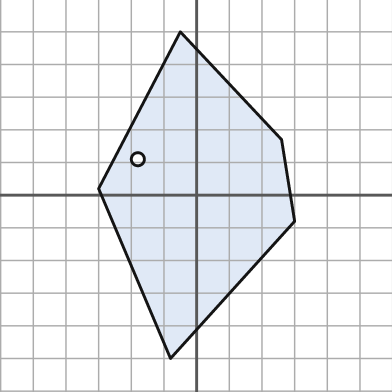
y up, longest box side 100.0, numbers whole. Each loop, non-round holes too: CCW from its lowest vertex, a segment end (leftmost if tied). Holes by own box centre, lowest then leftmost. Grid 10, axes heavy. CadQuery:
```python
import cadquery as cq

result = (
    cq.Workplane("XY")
    .moveTo(-8.0, -50.0)
    .lineTo(30.0, -8.0)
    .lineTo(26.0, 17.0)
    .lineTo(-5.0, 50.0)
    .lineTo(-30.0, 2.0)
    .close()
    .moveTo(-18.0, 11.0)
    .circle(2.0)
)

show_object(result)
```